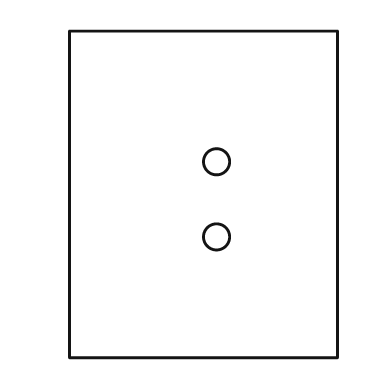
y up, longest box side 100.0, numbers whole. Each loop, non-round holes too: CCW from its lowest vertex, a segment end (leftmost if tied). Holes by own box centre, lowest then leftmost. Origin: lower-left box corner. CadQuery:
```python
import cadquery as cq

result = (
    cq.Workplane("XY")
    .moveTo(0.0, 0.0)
    .lineTo(82.0, 0.0)
    .lineTo(82.0, 100.0)
    .lineTo(0.0, 100.0)
    .close()
    .moveTo(45.0, 37.0)
    .circle(4.0)
    .moveTo(45.0, 60.0)
    .circle(4.0)
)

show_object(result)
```